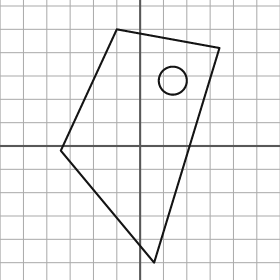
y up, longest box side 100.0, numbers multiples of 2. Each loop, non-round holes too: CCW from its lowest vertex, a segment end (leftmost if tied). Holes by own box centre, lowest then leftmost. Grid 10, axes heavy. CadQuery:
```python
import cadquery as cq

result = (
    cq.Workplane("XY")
    .moveTo(6.0, -50.0)
    .lineTo(34.0, 42.0)
    .lineTo(-10.0, 50.0)
    .lineTo(-34.0, -2.0)
    .close()
    .moveTo(14.0, 28.0)
    .circle(6.0)
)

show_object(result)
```